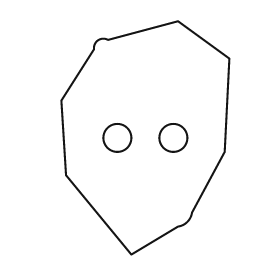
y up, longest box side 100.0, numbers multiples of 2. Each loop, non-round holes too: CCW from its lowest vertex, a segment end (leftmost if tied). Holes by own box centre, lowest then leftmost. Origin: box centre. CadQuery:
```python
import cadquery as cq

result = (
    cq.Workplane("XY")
    .moveTo(-6.0, -50.0)
    .lineTo(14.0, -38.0)
    .threePointArc((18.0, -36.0), (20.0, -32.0))
    .lineTo(34.0, -6.0)
    .lineTo(36.0, 34.0)
    .lineTo(14.0, 50.0)
    .lineTo(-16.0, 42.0)
    .threePointArc((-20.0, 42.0), (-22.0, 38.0))
    .lineTo(-36.0, 16.0)
    .lineTo(-34.0, -16.0)
    .close()
    .moveTo(-12.0, 0.0)
    .circle(6.0)
    .moveTo(12.0, 0.0)
    .circle(6.0)
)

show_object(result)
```